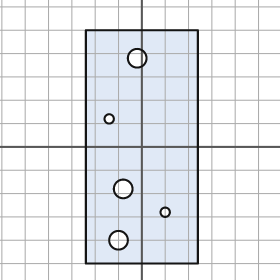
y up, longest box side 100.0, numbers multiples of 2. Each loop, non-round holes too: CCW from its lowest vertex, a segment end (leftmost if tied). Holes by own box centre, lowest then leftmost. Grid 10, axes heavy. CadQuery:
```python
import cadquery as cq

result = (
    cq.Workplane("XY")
    .moveTo(-24.0, -50.0)
    .lineTo(24.0, -50.0)
    .lineTo(24.0, 50.0)
    .lineTo(-24.0, 50.0)
    .close()
    .moveTo(-10.0, -40.0)
    .circle(4.0)
    .moveTo(10.0, -28.0)
    .circle(2.0)
    .moveTo(-8.0, -18.0)
    .circle(4.0)
    .moveTo(-14.0, 12.0)
    .circle(2.0)
    .moveTo(-2.0, 38.0)
    .circle(4.0)
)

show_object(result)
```